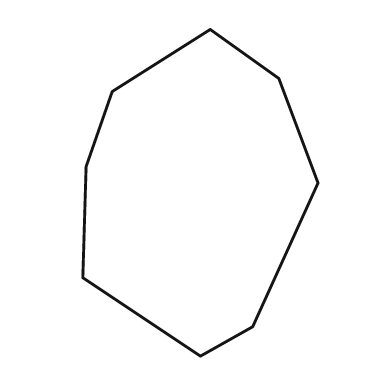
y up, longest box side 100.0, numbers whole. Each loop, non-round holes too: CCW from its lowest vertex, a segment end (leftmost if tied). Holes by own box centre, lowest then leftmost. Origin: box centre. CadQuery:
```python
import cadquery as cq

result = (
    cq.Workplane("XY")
    .moveTo(0.0, -50.0)
    .lineTo(16.0, -41.0)
    .lineTo(36.0, 3.0)
    .lineTo(24.0, 35.0)
    .lineTo(3.0, 50.0)
    .lineTo(-27.0, 31.0)
    .lineTo(-35.0, 8.0)
    .lineTo(-36.0, -26.0)
    .close()
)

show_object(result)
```